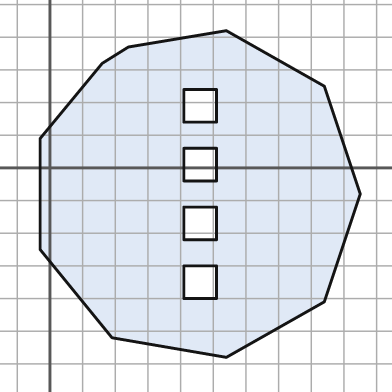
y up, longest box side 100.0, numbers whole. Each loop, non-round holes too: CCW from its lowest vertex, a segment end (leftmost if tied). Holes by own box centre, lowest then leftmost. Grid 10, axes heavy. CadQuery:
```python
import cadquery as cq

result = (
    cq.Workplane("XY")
    .moveTo(54.0, -58.0)
    .lineTo(84.0, -41.0)
    .lineTo(95.0, -8.0)
    .lineTo(84.0, 25.0)
    .lineTo(54.0, 42.0)
    .lineTo(24.0, 37.0)
    .lineTo(16.0, 32.0)
    .lineTo(-3.0, 9.0)
    .lineTo(-3.0, -25.0)
    .lineTo(19.0, -52.0)
    .close()
    .moveTo(41.0, -40.0)
    .lineTo(51.0, -40.0)
    .lineTo(51.0, -30.0)
    .lineTo(41.0, -30.0)
    .close()
    .moveTo(41.0, -22.0)
    .lineTo(51.0, -22.0)
    .lineTo(51.0, -12.0)
    .lineTo(41.0, -12.0)
    .close()
    .moveTo(41.0, -4.0)
    .lineTo(51.0, -4.0)
    .lineTo(51.0, 6.0)
    .lineTo(41.0, 6.0)
    .close()
    .moveTo(41.0, 14.0)
    .lineTo(51.0, 14.0)
    .lineTo(51.0, 24.0)
    .lineTo(41.0, 24.0)
    .close()
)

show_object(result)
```